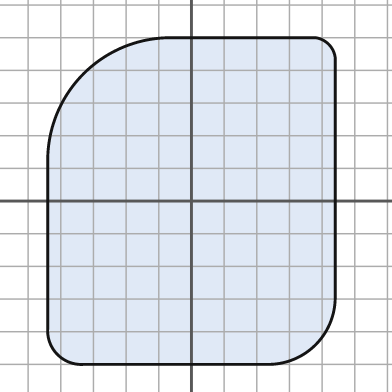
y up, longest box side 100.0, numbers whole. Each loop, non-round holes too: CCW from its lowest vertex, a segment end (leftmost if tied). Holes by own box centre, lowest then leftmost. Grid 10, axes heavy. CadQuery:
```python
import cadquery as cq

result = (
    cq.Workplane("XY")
    .moveTo(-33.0, -50.0)
    .lineTo(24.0, -50.0)
    .threePointArc((38.0, -44.0), (44.0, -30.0))
    .lineTo(44.0, 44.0)
    .threePointArc((42.0, 48.0), (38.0, 50.0))
    .lineTo(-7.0, 50.0)
    .threePointArc((-33.0, 39.0), (-44.0, 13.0))
    .lineTo(-44.0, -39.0)
    .threePointArc((-41.0, -47.0), (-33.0, -50.0))
    .close()
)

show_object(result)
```